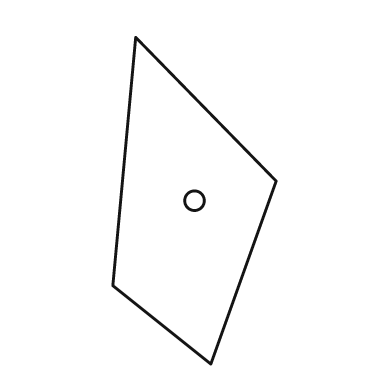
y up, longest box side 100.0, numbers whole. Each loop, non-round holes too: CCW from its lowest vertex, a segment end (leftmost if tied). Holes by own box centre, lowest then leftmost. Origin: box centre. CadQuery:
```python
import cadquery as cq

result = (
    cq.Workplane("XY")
    .moveTo(5.0, -50.0)
    .lineTo(25.0, 6.0)
    .lineTo(-18.0, 50.0)
    .lineTo(-25.0, -26.0)
    .close()
    .moveTo(0.0, 0.0)
    .circle(3.0)
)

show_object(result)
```